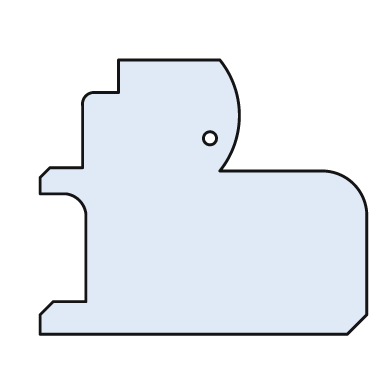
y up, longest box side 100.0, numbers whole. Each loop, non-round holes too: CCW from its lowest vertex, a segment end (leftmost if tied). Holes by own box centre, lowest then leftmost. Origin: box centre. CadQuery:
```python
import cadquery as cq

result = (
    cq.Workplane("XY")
    .moveTo(-50.0, -42.0)
    .lineTo(44.0, -42.0)
    .lineTo(50.0, -36.0)
    .lineTo(50.0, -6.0)
    .threePointArc((46.0, 4.0), (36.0, 8.0))
    .lineTo(5.0, 8.0)
    .threePointArc((11.0, 25.0), (5.0, 42.0))
    .lineTo(-26.0, 42.0)
    .lineTo(-26.0, 32.0)
    .lineTo(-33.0, 32.0)
    .threePointArc((-36.0, 31.0), (-37.0, 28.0))
    .lineTo(-37.0, 9.0)
    .lineTo(-47.0, 9.0)
    .lineTo(-50.0, 6.0)
    .lineTo(-50.0, 1.0)
    .lineTo(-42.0, 1.0)
    .threePointArc((-38.0, -1.0), (-36.0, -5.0))
    .lineTo(-36.0, -32.0)
    .lineTo(-46.0, -32.0)
    .lineTo(-50.0, -36.0)
    .close()
    .moveTo(2.0, 18.0)
    .circle(2.0)
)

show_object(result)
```